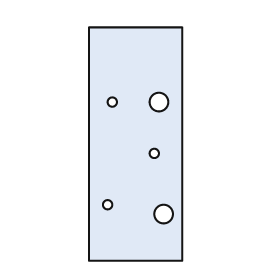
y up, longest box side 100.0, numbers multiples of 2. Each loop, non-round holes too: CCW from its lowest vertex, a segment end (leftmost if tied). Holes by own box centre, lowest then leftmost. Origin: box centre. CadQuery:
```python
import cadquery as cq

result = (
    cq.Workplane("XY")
    .moveTo(-20.0, -50.0)
    .lineTo(20.0, -50.0)
    .lineTo(20.0, 50.0)
    .lineTo(-20.0, 50.0)
    .close()
    .moveTo(12.0, -30.0)
    .circle(4.0)
    .moveTo(-12.0, -26.0)
    .circle(2.0)
    .moveTo(8.0, -4.0)
    .circle(2.0)
    .moveTo(-10.0, 18.0)
    .circle(2.0)
    .moveTo(10.0, 18.0)
    .circle(4.0)
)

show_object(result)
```